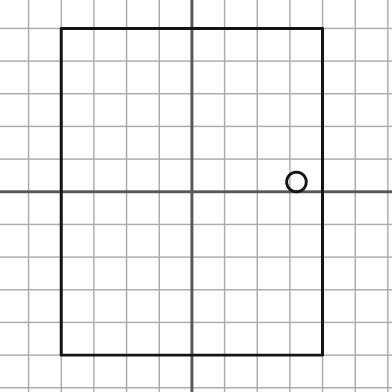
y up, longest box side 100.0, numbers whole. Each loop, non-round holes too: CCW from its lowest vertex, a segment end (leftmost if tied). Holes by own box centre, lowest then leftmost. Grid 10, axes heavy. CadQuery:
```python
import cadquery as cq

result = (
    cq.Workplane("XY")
    .moveTo(-40.0, -50.0)
    .lineTo(40.0, -50.0)
    .lineTo(40.0, 50.0)
    .lineTo(-40.0, 50.0)
    .close()
    .moveTo(32.0, 3.0)
    .circle(3.0)
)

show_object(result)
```